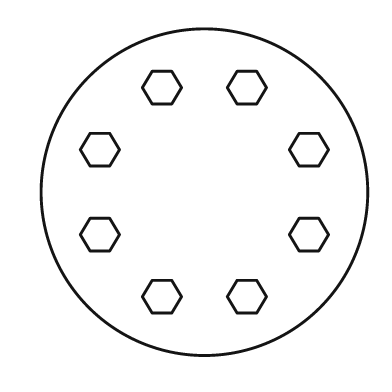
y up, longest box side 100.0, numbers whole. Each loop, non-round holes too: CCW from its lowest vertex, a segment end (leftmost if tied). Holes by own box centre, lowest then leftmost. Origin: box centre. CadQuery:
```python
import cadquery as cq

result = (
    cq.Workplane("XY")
    .moveTo(0.0, 0.0)
    .circle(50.0)
    .moveTo(-16.0, -37.0)
    .lineTo(-10.0, -37.0)
    .lineTo(-7.0, -32.0)
    .lineTo(-10.0, -27.0)
    .lineTo(-16.0, -27.0)
    .lineTo(-19.0, -32.0)
    .close()
    .moveTo(10.0, -37.0)
    .lineTo(16.0, -37.0)
    .lineTo(19.0, -32.0)
    .lineTo(16.0, -27.0)
    .lineTo(10.0, -27.0)
    .lineTo(7.0, -32.0)
    .close()
    .moveTo(-35.0, -18.0)
    .lineTo(-29.0, -18.0)
    .lineTo(-26.0, -13.0)
    .lineTo(-29.0, -8.0)
    .lineTo(-35.0, -8.0)
    .lineTo(-38.0, -13.0)
    .close()
    .moveTo(29.0, -18.0)
    .lineTo(35.0, -18.0)
    .lineTo(38.0, -13.0)
    .lineTo(35.0, -8.0)
    .lineTo(29.0, -8.0)
    .lineTo(26.0, -13.0)
    .close()
    .moveTo(-35.0, 8.0)
    .lineTo(-29.0, 8.0)
    .lineTo(-26.0, 13.0)
    .lineTo(-29.0, 18.0)
    .lineTo(-35.0, 18.0)
    .lineTo(-38.0, 13.0)
    .close()
    .moveTo(29.0, 8.0)
    .lineTo(35.0, 8.0)
    .lineTo(38.0, 13.0)
    .lineTo(35.0, 18.0)
    .lineTo(29.0, 18.0)
    .lineTo(26.0, 13.0)
    .close()
    .moveTo(-16.0, 27.0)
    .lineTo(-10.0, 27.0)
    .lineTo(-7.0, 32.0)
    .lineTo(-10.0, 37.0)
    .lineTo(-16.0, 37.0)
    .lineTo(-19.0, 32.0)
    .close()
    .moveTo(10.0, 27.0)
    .lineTo(16.0, 27.0)
    .lineTo(19.0, 32.0)
    .lineTo(16.0, 37.0)
    .lineTo(10.0, 37.0)
    .lineTo(7.0, 32.0)
    .close()
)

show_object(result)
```